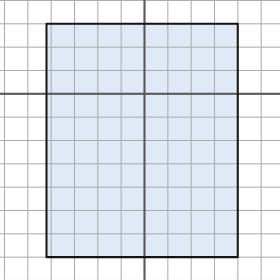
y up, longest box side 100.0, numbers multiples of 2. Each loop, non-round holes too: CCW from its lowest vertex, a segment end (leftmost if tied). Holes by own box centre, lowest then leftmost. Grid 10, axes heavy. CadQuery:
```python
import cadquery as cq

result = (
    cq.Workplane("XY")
    .moveTo(-42.0, -70.0)
    .lineTo(40.0, -70.0)
    .lineTo(40.0, 30.0)
    .lineTo(-42.0, 30.0)
    .close()
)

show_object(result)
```